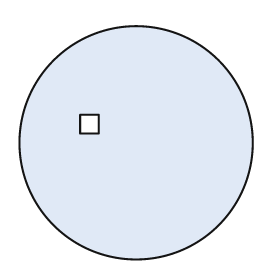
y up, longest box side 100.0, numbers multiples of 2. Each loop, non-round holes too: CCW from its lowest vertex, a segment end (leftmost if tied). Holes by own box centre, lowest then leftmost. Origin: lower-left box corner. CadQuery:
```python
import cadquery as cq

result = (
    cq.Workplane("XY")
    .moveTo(50.0, 50.0)
    .circle(50.0)
    .moveTo(26.0, 54.0)
    .lineTo(34.0, 54.0)
    .lineTo(34.0, 62.0)
    .lineTo(26.0, 62.0)
    .close()
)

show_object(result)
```